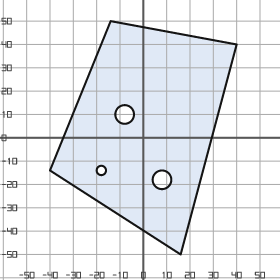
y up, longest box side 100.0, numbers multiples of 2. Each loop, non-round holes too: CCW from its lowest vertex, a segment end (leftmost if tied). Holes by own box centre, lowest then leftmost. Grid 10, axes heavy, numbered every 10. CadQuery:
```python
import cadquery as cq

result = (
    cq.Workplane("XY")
    .moveTo(16.0, -50.0)
    .lineTo(40.0, 40.0)
    .lineTo(-14.0, 50.0)
    .lineTo(-40.0, -14.0)
    .close()
    .moveTo(8.0, -18.0)
    .circle(4.0)
    .moveTo(-18.0, -14.0)
    .circle(2.0)
    .moveTo(-8.0, 10.0)
    .circle(4.0)
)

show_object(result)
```